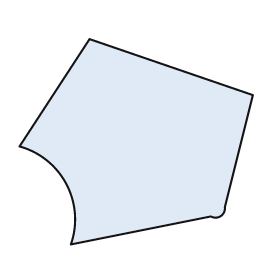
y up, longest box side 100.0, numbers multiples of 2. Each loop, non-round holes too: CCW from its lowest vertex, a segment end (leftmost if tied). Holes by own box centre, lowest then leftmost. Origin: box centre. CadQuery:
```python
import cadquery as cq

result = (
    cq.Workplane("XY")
    .moveTo(-28.0, -44.0)
    .lineTo(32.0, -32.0)
    .threePointArc((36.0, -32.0), (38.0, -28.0))
    .lineTo(50.0, 20.0)
    .lineTo(-20.0, 44.0)
    .lineTo(-50.0, -2.0)
    .threePointArc((-30.0, -18.0), (-28.0, -44.0))
    .close()
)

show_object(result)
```